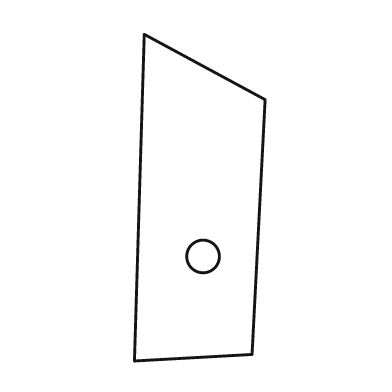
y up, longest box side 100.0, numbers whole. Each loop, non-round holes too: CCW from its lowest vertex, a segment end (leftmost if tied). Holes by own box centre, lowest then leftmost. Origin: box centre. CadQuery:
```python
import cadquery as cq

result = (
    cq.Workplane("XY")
    .moveTo(-20.0, -50.0)
    .lineTo(16.0, -48.0)
    .lineTo(20.0, 30.0)
    .lineTo(-17.0, 50.0)
    .close()
    .moveTo(1.0, -18.0)
    .circle(5.0)
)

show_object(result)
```